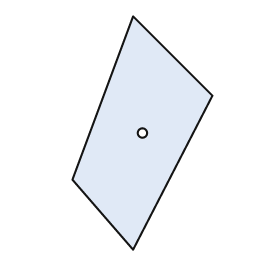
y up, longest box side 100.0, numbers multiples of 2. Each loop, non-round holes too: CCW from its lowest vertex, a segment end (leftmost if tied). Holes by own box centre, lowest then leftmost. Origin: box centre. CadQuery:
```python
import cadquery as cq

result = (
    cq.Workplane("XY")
    .moveTo(-4.0, -50.0)
    .lineTo(30.0, 16.0)
    .lineTo(-4.0, 50.0)
    .lineTo(-30.0, -20.0)
    .close()
    .moveTo(0.0, 0.0)
    .circle(2.0)
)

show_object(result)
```